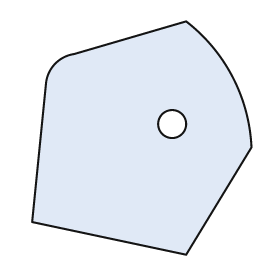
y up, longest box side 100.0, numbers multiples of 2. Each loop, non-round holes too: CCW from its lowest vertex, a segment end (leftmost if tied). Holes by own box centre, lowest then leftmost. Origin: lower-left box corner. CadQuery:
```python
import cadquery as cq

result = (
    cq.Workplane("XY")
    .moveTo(66.0, 0.0)
    .lineTo(94.0, 46.0)
    .threePointArc((86.0, 76.0), (66.0, 100.0))
    .lineTo(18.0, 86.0)
    .threePointArc((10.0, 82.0), (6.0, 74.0))
    .lineTo(0.0, 14.0)
    .close()
    .moveTo(60.0, 56.0)
    .circle(6.0)
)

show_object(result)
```